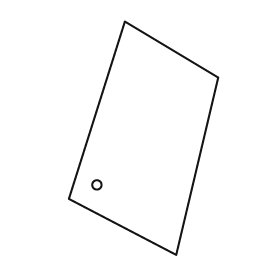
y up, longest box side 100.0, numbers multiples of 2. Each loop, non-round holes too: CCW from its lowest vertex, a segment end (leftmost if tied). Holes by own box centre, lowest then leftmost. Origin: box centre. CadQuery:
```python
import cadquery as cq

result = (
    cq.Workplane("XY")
    .moveTo(14.0, -50.0)
    .lineTo(32.0, 26.0)
    .lineTo(-8.0, 50.0)
    .lineTo(-32.0, -26.0)
    .close()
    .moveTo(-20.0, -20.0)
    .circle(2.0)
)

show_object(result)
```